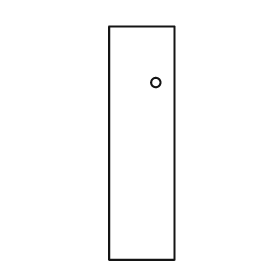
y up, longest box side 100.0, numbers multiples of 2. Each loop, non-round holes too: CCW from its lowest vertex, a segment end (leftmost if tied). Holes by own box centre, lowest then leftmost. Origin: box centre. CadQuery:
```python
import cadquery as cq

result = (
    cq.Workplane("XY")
    .moveTo(-14.0, -50.0)
    .lineTo(14.0, -50.0)
    .lineTo(14.0, 50.0)
    .lineTo(-14.0, 50.0)
    .close()
    .moveTo(6.0, 26.0)
    .circle(2.0)
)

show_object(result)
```